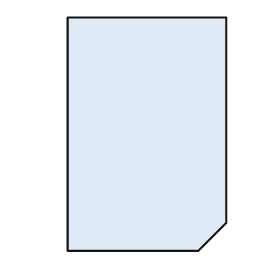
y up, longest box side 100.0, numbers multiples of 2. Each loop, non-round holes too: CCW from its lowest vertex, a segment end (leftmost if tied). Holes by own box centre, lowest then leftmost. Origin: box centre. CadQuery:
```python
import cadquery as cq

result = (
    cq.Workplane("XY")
    .moveTo(-34.0, -50.0)
    .lineTo(22.0, -50.0)
    .lineTo(34.0, -38.0)
    .lineTo(34.0, 50.0)
    .lineTo(-34.0, 50.0)
    .close()
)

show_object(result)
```